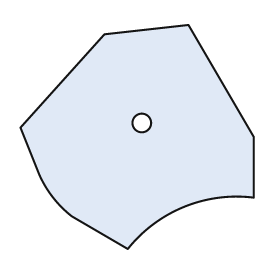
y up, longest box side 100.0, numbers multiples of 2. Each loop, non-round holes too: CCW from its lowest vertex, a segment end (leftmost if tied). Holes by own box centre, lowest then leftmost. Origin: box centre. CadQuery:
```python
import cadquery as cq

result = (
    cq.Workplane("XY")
    .moveTo(-4.0, -48.0)
    .threePointArc((20.0, -30.0), (50.0, -26.0))
    .lineTo(50.0, 0.0)
    .lineTo(22.0, 48.0)
    .lineTo(-14.0, 44.0)
    .lineTo(-50.0, 4.0)
    .lineTo(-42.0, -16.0)
    .threePointArc((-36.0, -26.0), (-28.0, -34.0))
    .close()
    .moveTo(2.0, 6.0)
    .circle(4.0)
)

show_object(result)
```